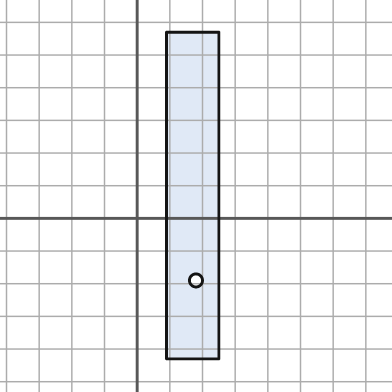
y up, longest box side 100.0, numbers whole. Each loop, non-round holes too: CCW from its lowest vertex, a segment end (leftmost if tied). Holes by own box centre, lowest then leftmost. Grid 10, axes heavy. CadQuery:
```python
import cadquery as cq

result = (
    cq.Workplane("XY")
    .moveTo(9.0, -43.0)
    .lineTo(25.0, -43.0)
    .lineTo(25.0, 57.0)
    .lineTo(9.0, 57.0)
    .close()
    .moveTo(18.0, -19.0)
    .circle(2.0)
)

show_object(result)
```